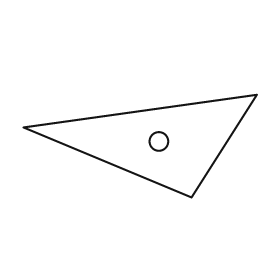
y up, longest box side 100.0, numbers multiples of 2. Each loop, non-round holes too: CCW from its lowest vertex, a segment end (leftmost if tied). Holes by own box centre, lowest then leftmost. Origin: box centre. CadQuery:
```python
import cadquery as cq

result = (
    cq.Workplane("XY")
    .moveTo(22.0, -22.0)
    .lineTo(50.0, 22.0)
    .lineTo(-50.0, 8.0)
    .close()
    .moveTo(8.0, 2.0)
    .circle(4.0)
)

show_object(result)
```